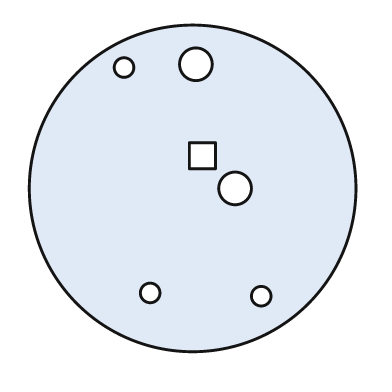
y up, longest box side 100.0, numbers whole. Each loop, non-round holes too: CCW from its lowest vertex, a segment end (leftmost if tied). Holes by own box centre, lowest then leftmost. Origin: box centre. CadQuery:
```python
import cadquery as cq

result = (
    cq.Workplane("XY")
    .moveTo(0.0, 0.0)
    .circle(50.0)
    .moveTo(21.0, -33.0)
    .circle(3.0)
    .moveTo(-13.0, -32.0)
    .circle(3.0)
    .moveTo(13.0, 0.0)
    .circle(5.0)
    .moveTo(-1.0, 6.0)
    .lineTo(7.0, 6.0)
    .lineTo(7.0, 14.0)
    .lineTo(-1.0, 14.0)
    .close()
    .moveTo(-21.0, 37.0)
    .circle(3.0)
    .moveTo(1.0, 38.0)
    .circle(5.0)
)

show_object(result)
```